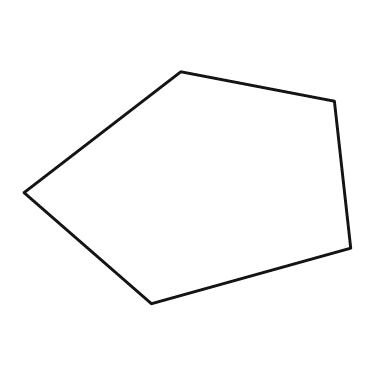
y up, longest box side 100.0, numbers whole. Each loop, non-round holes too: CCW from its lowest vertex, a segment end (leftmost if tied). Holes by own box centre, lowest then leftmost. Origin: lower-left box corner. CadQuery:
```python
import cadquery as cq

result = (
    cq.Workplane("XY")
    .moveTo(39.0, 0.0)
    .lineTo(100.0, 17.0)
    .lineTo(95.0, 62.0)
    .lineTo(48.0, 71.0)
    .lineTo(0.0, 34.0)
    .close()
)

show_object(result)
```